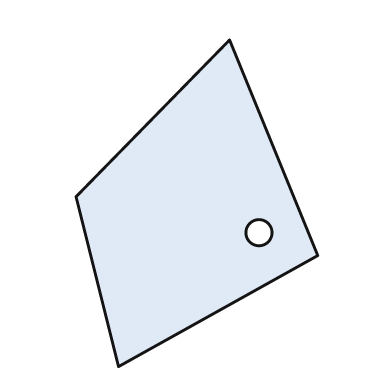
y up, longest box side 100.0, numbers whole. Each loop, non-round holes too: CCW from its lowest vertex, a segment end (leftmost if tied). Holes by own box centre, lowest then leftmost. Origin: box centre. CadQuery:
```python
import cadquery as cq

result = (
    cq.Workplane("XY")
    .moveTo(-24.0, -50.0)
    .lineTo(37.0, -16.0)
    .lineTo(10.0, 50.0)
    .lineTo(-37.0, 2.0)
    .close()
    .moveTo(19.0, -9.0)
    .circle(4.0)
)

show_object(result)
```